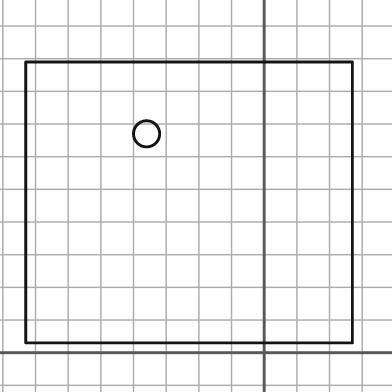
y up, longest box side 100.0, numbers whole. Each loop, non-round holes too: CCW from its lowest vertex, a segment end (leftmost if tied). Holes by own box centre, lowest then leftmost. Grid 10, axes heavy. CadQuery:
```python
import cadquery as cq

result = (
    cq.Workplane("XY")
    .moveTo(-73.0, 3.0)
    .lineTo(27.0, 3.0)
    .lineTo(27.0, 89.0)
    .lineTo(-73.0, 89.0)
    .close()
    .moveTo(-36.0, 67.0)
    .circle(4.0)
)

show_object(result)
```